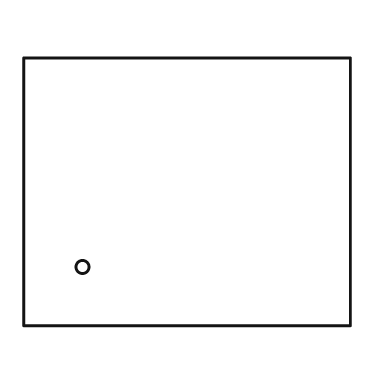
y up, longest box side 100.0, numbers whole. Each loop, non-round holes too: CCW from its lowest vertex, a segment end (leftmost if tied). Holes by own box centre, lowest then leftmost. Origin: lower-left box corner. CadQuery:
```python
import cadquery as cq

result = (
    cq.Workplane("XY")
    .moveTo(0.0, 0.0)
    .lineTo(100.0, 0.0)
    .lineTo(100.0, 82.0)
    .lineTo(0.0, 82.0)
    .close()
    .moveTo(18.0, 18.0)
    .circle(2.0)
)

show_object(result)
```